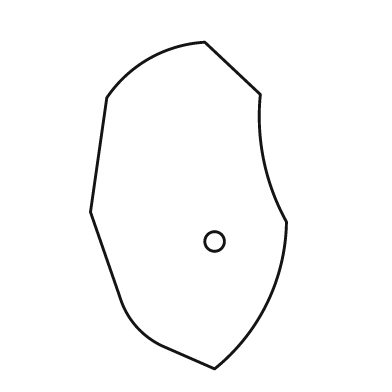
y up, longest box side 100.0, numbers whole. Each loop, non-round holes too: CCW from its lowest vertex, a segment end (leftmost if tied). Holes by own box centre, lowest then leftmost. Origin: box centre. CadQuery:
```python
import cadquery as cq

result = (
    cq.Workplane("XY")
    .moveTo(8.0, -50.0)
    .threePointArc((24.0, -30.0), (30.0, -5.0))
    .threePointArc((23.0, 14.0), (22.0, 34.0))
    .lineTo(5.0, 50.0)
    .threePointArc((-12.0, 45.0), (-25.0, 33.0))
    .lineTo(-30.0, -2.0)
    .lineTo(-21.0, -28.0)
    .threePointArc((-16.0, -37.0), (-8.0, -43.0))
    .close()
    .moveTo(8.0, -11.0)
    .circle(3.0)
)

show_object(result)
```